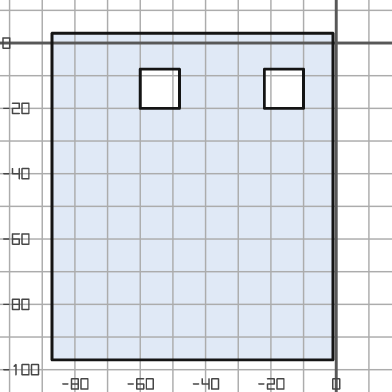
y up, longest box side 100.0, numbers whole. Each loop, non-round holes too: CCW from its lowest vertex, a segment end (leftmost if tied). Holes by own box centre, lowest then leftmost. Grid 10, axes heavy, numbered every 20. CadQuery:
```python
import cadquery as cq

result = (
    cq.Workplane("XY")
    .moveTo(-87.0, -97.0)
    .lineTo(-1.0, -97.0)
    .lineTo(-1.0, 3.0)
    .lineTo(-87.0, 3.0)
    .close()
    .moveTo(-60.0, -20.0)
    .lineTo(-48.0, -20.0)
    .lineTo(-48.0, -8.0)
    .lineTo(-60.0, -8.0)
    .close()
    .moveTo(-22.0, -20.0)
    .lineTo(-10.0, -20.0)
    .lineTo(-10.0, -8.0)
    .lineTo(-22.0, -8.0)
    .close()
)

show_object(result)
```